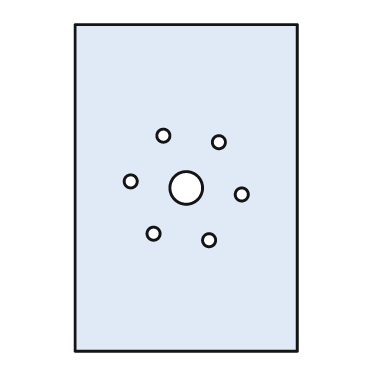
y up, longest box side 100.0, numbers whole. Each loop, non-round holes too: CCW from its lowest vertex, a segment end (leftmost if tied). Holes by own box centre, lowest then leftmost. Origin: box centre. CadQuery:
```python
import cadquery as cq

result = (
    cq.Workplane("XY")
    .moveTo(-34.0, -50.0)
    .lineTo(34.0, -50.0)
    .lineTo(34.0, 50.0)
    .lineTo(-34.0, 50.0)
    .close()
    .moveTo(7.0, -16.0)
    .circle(2.0)
    .moveTo(-10.0, -14.0)
    .circle(2.0)
    .moveTo(17.0, -2.0)
    .circle(2.0)
    .moveTo(0.0, 0.0)
    .circle(5.0)
    .moveTo(-17.0, 2.0)
    .circle(2.0)
    .moveTo(10.0, 14.0)
    .circle(2.0)
    .moveTo(-7.0, 16.0)
    .circle(2.0)
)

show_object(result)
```